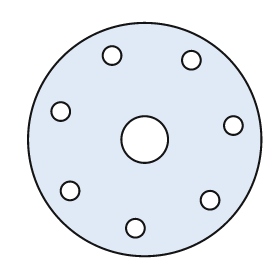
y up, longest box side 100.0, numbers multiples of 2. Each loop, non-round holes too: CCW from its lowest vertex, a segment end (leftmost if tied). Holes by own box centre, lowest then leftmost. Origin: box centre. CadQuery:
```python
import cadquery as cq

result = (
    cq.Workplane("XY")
    .moveTo(0.0, 0.0)
    .circle(50.0)
    .moveTo(-4.0, -38.0)
    .circle(4.0)
    .moveTo(28.0, -26.0)
    .circle(4.0)
    .moveTo(-32.0, -22.0)
    .circle(4.0)
    .moveTo(0.0, 0.0)
    .circle(10.0)
    .moveTo(38.0, 6.0)
    .circle(4.0)
    .moveTo(-36.0, 12.0)
    .circle(4.0)
    .moveTo(20.0, 34.0)
    .circle(4.0)
    .moveTo(-14.0, 36.0)
    .circle(4.0)
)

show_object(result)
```